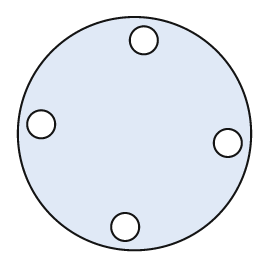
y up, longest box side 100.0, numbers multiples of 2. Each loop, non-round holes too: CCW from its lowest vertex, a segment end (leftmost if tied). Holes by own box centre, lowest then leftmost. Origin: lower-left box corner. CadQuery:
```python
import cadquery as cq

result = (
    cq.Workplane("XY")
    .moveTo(50.0, 50.0)
    .circle(50.0)
    .moveTo(46.0, 10.0)
    .circle(6.0)
    .moveTo(90.0, 46.0)
    .circle(6.0)
    .moveTo(10.0, 54.0)
    .circle(6.0)
    .moveTo(54.0, 90.0)
    .circle(6.0)
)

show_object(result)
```